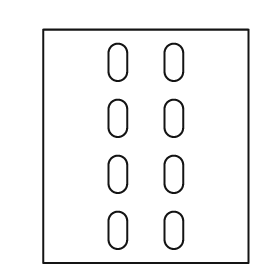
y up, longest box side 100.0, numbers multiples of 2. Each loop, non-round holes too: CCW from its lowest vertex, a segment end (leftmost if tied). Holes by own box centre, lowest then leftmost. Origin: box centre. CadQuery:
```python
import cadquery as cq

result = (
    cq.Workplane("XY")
    .moveTo(-44.0, -50.0)
    .lineTo(44.0, -50.0)
    .lineTo(44.0, 50.0)
    .lineTo(-44.0, 50.0)
    .close()
    .moveTo(-16.0, -40.0)
    .threePointArc((-12.0, -44.0), (-8.0, -40.0))
    .lineTo(-8.0, -32.0)
    .threePointArc((-12.0, -28.0), (-16.0, -32.0))
    .close()
    .moveTo(8.0, -40.0)
    .threePointArc((12.0, -44.0), (16.0, -40.0))
    .lineTo(16.0, -32.0)
    .threePointArc((12.0, -28.0), (8.0, -32.0))
    .close()
    .moveTo(-16.0, -16.0)
    .threePointArc((-12.0, -20.0), (-8.0, -16.0))
    .lineTo(-8.0, -8.0)
    .threePointArc((-12.0, -4.0), (-16.0, -8.0))
    .close()
    .moveTo(8.0, -16.0)
    .threePointArc((12.0, -20.0), (16.0, -16.0))
    .lineTo(16.0, -8.0)
    .threePointArc((12.0, -4.0), (8.0, -8.0))
    .close()
    .moveTo(-16.0, 8.0)
    .threePointArc((-12.0, 4.0), (-8.0, 8.0))
    .lineTo(-8.0, 16.0)
    .threePointArc((-12.0, 20.0), (-16.0, 16.0))
    .close()
    .moveTo(8.0, 8.0)
    .threePointArc((12.0, 4.0), (16.0, 8.0))
    .lineTo(16.0, 16.0)
    .threePointArc((12.0, 20.0), (8.0, 16.0))
    .close()
    .moveTo(-16.0, 32.0)
    .threePointArc((-12.0, 28.0), (-8.0, 32.0))
    .lineTo(-8.0, 40.0)
    .threePointArc((-12.0, 44.0), (-16.0, 40.0))
    .close()
    .moveTo(8.0, 32.0)
    .threePointArc((12.0, 28.0), (16.0, 32.0))
    .lineTo(16.0, 40.0)
    .threePointArc((12.0, 44.0), (8.0, 40.0))
    .close()
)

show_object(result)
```